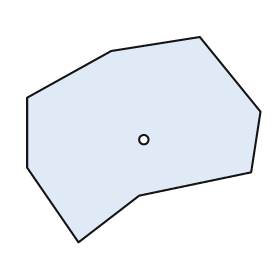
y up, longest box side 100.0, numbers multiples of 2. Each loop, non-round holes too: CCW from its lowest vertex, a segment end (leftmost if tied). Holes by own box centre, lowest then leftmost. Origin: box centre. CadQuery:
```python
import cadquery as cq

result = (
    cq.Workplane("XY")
    .moveTo(-28.0, -44.0)
    .lineTo(-2.0, -24.0)
    .lineTo(46.0, -14.0)
    .lineTo(50.0, 12.0)
    .lineTo(24.0, 44.0)
    .lineTo(-14.0, 38.0)
    .lineTo(-50.0, 18.0)
    .lineTo(-50.0, -12.0)
    .close()
    .moveTo(0.0, 0.0)
    .circle(2.0)
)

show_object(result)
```